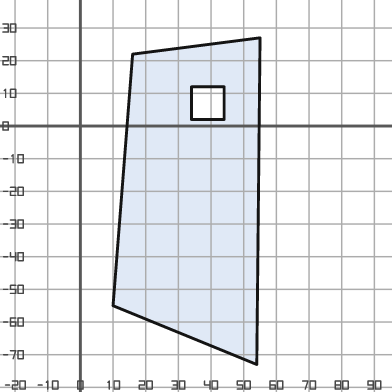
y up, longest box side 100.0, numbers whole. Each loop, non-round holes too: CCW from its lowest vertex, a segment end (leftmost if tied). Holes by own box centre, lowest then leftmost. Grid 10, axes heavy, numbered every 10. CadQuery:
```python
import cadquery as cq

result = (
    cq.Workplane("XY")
    .moveTo(54.0, -73.0)
    .lineTo(55.0, 27.0)
    .lineTo(16.0, 22.0)
    .lineTo(10.0, -55.0)
    .close()
    .moveTo(34.0, 2.0)
    .lineTo(44.0, 2.0)
    .lineTo(44.0, 12.0)
    .lineTo(34.0, 12.0)
    .close()
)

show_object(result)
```